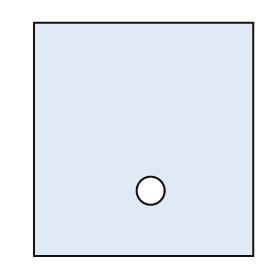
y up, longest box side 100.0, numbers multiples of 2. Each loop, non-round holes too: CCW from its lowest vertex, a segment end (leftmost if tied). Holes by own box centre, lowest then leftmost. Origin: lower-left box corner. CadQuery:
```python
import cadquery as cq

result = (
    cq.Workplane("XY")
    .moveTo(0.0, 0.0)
    .lineTo(94.0, 0.0)
    .lineTo(94.0, 100.0)
    .lineTo(0.0, 100.0)
    .close()
    .moveTo(50.0, 28.0)
    .circle(6.0)
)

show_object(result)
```